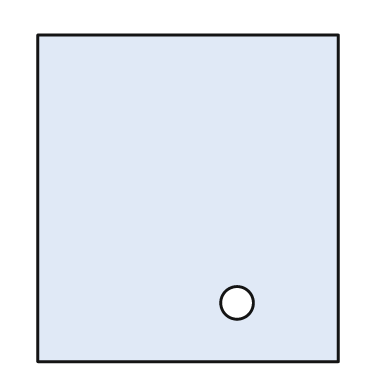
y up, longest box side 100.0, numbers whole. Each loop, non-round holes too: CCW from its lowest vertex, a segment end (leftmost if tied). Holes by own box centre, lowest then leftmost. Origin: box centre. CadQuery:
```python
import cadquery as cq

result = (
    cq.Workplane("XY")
    .moveTo(-46.0, -50.0)
    .lineTo(46.0, -50.0)
    .lineTo(46.0, 50.0)
    .lineTo(-46.0, 50.0)
    .close()
    .moveTo(15.0, -32.0)
    .circle(5.0)
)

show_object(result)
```